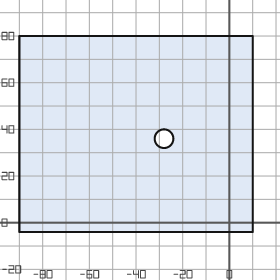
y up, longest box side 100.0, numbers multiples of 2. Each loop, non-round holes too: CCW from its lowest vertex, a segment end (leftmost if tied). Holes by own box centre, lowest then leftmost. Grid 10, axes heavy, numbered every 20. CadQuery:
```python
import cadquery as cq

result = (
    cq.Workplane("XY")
    .moveTo(-90.0, -4.0)
    .lineTo(10.0, -4.0)
    .lineTo(10.0, 80.0)
    .lineTo(-90.0, 80.0)
    .close()
    .moveTo(-28.0, 36.0)
    .circle(4.0)
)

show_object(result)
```